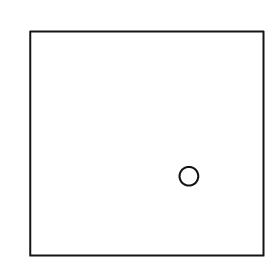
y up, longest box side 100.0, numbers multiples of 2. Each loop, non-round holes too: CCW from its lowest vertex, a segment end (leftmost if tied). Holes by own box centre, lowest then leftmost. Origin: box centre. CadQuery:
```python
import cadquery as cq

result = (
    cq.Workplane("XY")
    .moveTo(-50.0, -48.0)
    .lineTo(50.0, -48.0)
    .lineTo(50.0, 48.0)
    .lineTo(-50.0, 48.0)
    .close()
    .moveTo(18.0, -14.0)
    .circle(4.0)
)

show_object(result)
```